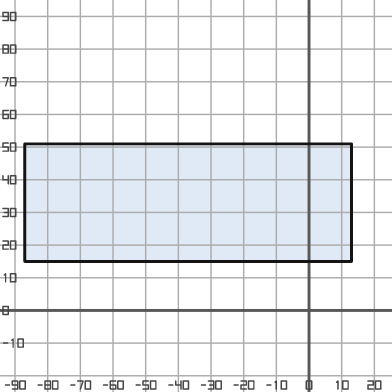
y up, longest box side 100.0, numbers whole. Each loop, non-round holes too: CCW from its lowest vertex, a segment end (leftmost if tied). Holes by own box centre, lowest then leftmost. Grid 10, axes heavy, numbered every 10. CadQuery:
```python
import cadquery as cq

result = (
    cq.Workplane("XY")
    .moveTo(-87.0, 15.0)
    .lineTo(13.0, 15.0)
    .lineTo(13.0, 51.0)
    .lineTo(-87.0, 51.0)
    .close()
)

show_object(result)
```